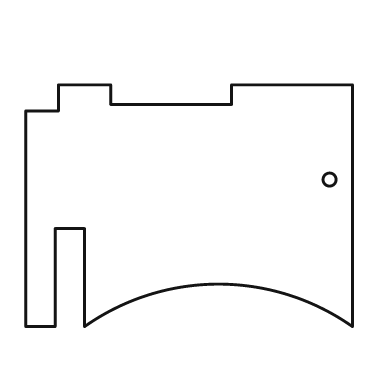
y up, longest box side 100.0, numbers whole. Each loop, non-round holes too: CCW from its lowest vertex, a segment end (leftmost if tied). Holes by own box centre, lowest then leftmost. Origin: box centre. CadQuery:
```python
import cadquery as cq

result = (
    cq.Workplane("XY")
    .moveTo(-50.0, -37.0)
    .lineTo(-41.0, -37.0)
    .lineTo(-41.0, -7.0)
    .lineTo(-32.0, -7.0)
    .lineTo(-32.0, -37.0)
    .threePointArc((9.0, -24.0), (50.0, -37.0))
    .lineTo(50.0, 37.0)
    .lineTo(13.0, 37.0)
    .lineTo(13.0, 31.0)
    .lineTo(-24.0, 31.0)
    .lineTo(-24.0, 37.0)
    .lineTo(-40.0, 37.0)
    .lineTo(-40.0, 29.0)
    .lineTo(-50.0, 29.0)
    .close()
    .moveTo(43.0, 8.0)
    .circle(2.0)
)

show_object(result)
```